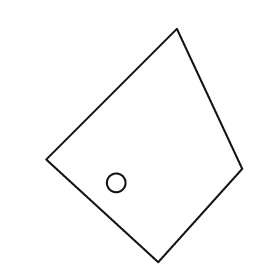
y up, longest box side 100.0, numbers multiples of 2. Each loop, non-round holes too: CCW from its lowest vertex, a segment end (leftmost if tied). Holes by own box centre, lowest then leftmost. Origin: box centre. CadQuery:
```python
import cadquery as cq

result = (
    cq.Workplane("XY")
    .moveTo(6.0, -50.0)
    .lineTo(42.0, -10.0)
    .lineTo(14.0, 50.0)
    .lineTo(-42.0, -6.0)
    .close()
    .moveTo(-12.0, -16.0)
    .circle(4.0)
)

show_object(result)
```